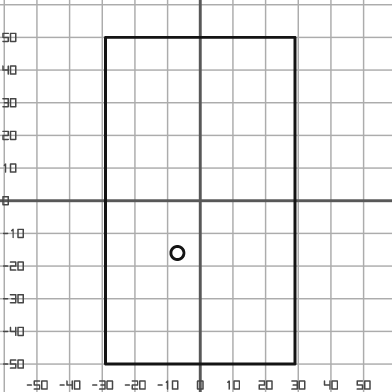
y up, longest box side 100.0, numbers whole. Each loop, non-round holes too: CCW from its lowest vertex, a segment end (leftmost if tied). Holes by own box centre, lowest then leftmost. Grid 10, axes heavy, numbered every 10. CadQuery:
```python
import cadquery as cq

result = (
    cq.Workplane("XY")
    .moveTo(-29.0, -50.0)
    .lineTo(29.0, -50.0)
    .lineTo(29.0, 50.0)
    .lineTo(-29.0, 50.0)
    .close()
    .moveTo(-7.0, -16.0)
    .circle(2.0)
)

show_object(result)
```